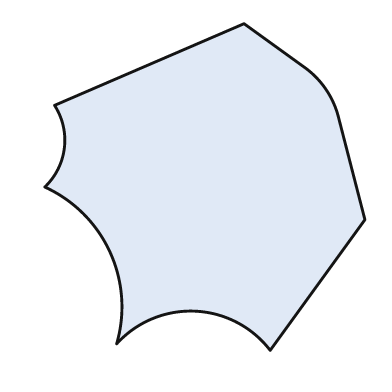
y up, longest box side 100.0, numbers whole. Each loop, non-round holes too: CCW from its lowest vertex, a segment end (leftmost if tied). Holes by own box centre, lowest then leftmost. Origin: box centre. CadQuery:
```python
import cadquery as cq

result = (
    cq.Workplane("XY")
    .moveTo(20.0, -50.0)
    .lineTo(49.0, -10.0)
    .lineTo(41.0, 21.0)
    .threePointArc((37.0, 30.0), (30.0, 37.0))
    .lineTo(12.0, 50.0)
    .lineTo(-46.0, 25.0)
    .threePointArc((-43.0, 12.0), (-49.0, 0.0))
    .threePointArc((-29.0, -20.0), (-27.0, -48.0))
    .threePointArc((-3.0, -38.0), (20.0, -50.0))
    .close()
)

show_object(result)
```